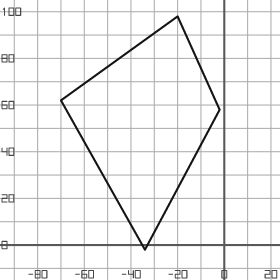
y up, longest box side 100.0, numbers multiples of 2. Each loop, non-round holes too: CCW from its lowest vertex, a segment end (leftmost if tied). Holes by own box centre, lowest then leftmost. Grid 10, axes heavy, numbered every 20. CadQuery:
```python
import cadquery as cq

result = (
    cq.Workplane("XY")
    .moveTo(-34.0, -2.0)
    .lineTo(-2.0, 58.0)
    .lineTo(-20.0, 98.0)
    .lineTo(-70.0, 62.0)
    .close()
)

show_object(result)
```